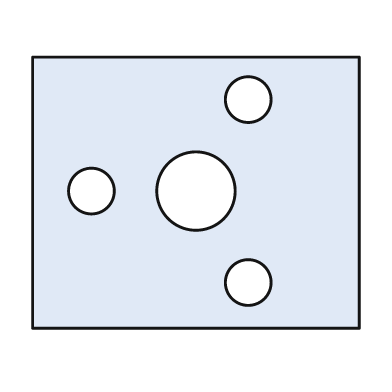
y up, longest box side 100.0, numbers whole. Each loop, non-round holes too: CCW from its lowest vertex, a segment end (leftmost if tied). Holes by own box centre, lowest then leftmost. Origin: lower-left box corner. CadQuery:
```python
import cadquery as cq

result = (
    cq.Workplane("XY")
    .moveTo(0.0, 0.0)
    .lineTo(100.0, 0.0)
    .lineTo(100.0, 83.0)
    .lineTo(0.0, 83.0)
    .close()
    .moveTo(66.0, 14.0)
    .circle(7.0)
    .moveTo(18.0, 42.0)
    .circle(7.0)
    .moveTo(50.0, 42.0)
    .circle(12.0)
    .moveTo(66.0, 70.0)
    .circle(7.0)
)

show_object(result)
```